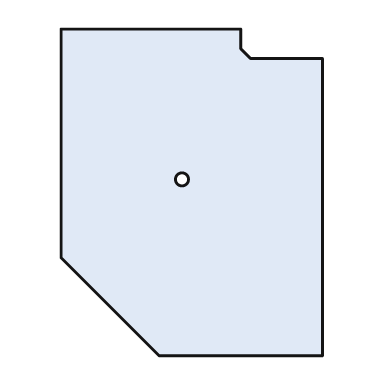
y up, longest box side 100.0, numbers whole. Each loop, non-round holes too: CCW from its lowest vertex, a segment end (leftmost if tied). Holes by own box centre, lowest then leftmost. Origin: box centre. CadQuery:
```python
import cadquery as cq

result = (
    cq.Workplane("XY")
    .moveTo(-10.0, -50.0)
    .lineTo(40.0, -50.0)
    .lineTo(40.0, 41.0)
    .lineTo(18.0, 41.0)
    .lineTo(15.0, 44.0)
    .lineTo(15.0, 50.0)
    .lineTo(-40.0, 50.0)
    .lineTo(-40.0, -20.0)
    .close()
    .moveTo(-3.0, 4.0)
    .circle(2.0)
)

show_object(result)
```